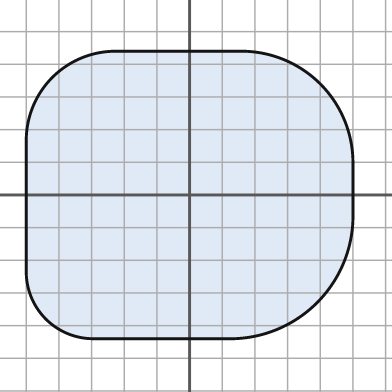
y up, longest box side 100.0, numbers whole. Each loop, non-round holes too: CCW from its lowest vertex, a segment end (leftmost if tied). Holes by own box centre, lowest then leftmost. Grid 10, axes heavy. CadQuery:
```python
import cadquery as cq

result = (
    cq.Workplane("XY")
    .moveTo(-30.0, -44.0)
    .lineTo(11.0, -44.0)
    .threePointArc((39.0, -33.0), (50.0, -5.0))
    .lineTo(50.0, 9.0)
    .threePointArc((40.0, 34.0), (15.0, 44.0))
    .lineTo(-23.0, 44.0)
    .threePointArc((-42.0, 36.0), (-50.0, 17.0))
    .lineTo(-50.0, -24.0)
    .threePointArc((-44.0, -38.0), (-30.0, -44.0))
    .close()
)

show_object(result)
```